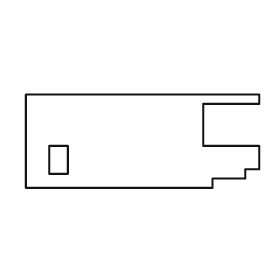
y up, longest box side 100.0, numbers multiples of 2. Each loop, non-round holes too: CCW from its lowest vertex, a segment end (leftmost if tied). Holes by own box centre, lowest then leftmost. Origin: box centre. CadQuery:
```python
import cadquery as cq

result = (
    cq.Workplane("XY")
    .moveTo(-50.0, -20.0)
    .lineTo(30.0, -20.0)
    .lineTo(30.0, -16.0)
    .lineTo(44.0, -16.0)
    .lineTo(44.0, -12.0)
    .lineTo(50.0, -12.0)
    .lineTo(50.0, -2.0)
    .lineTo(26.0, -2.0)
    .lineTo(26.0, 16.0)
    .lineTo(50.0, 16.0)
    .lineTo(50.0, 20.0)
    .lineTo(-50.0, 20.0)
    .close()
    .moveTo(-40.0, -14.0)
    .lineTo(-32.0, -14.0)
    .lineTo(-32.0, -2.0)
    .lineTo(-40.0, -2.0)
    .close()
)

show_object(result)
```